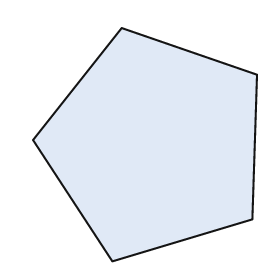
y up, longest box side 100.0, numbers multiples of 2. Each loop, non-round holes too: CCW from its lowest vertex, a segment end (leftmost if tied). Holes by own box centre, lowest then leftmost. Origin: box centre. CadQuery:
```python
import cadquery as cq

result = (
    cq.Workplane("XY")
    .moveTo(-14.0, -50.0)
    .lineTo(46.0, -32.0)
    .lineTo(48.0, 30.0)
    .lineTo(-10.0, 50.0)
    .lineTo(-48.0, 2.0)
    .close()
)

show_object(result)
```